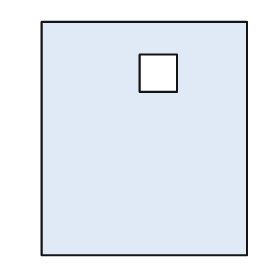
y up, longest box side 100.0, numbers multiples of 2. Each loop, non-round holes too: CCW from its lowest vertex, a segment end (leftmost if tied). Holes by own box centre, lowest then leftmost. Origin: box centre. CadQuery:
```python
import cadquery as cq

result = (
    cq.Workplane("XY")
    .moveTo(-44.0, -50.0)
    .lineTo(44.0, -50.0)
    .lineTo(44.0, 50.0)
    .lineTo(-44.0, 50.0)
    .close()
    .moveTo(-2.0, 20.0)
    .lineTo(14.0, 20.0)
    .lineTo(14.0, 36.0)
    .lineTo(-2.0, 36.0)
    .close()
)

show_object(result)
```